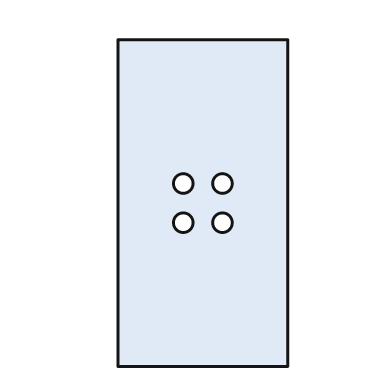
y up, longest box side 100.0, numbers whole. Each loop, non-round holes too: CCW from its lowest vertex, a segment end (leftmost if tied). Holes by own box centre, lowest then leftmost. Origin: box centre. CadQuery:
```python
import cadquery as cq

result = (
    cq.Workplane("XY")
    .moveTo(-26.0, -50.0)
    .lineTo(26.0, -50.0)
    .lineTo(26.0, 50.0)
    .lineTo(-26.0, 50.0)
    .close()
    .moveTo(-6.0, -6.0)
    .circle(3.0)
    .moveTo(6.0, -6.0)
    .circle(3.0)
    .moveTo(-6.0, 6.0)
    .circle(3.0)
    .moveTo(6.0, 6.0)
    .circle(3.0)
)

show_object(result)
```